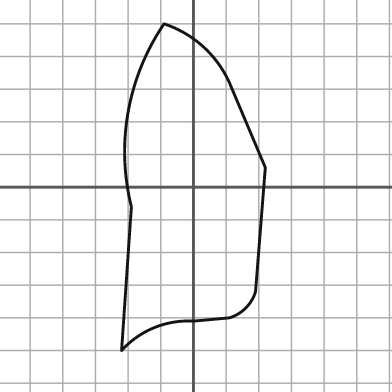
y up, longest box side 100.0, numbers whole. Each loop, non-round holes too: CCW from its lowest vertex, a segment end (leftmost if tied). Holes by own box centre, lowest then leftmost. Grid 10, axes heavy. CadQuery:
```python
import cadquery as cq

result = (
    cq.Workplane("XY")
    .moveTo(-22.0, -50.0)
    .threePointArc((-12.0, -43.0), (0.0, -41.0))
    .lineTo(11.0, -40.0)
    .threePointArc((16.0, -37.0), (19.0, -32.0))
    .lineTo(22.0, 6.0)
    .lineTo(11.0, 32.0)
    .threePointArc((3.0, 43.0), (-9.0, 50.0))
    .threePointArc((-20.0, 23.0), (-19.0, -6.0))
    .close()
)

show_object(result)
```